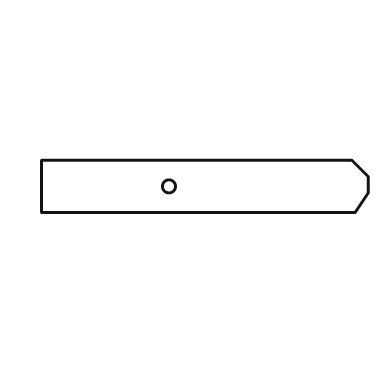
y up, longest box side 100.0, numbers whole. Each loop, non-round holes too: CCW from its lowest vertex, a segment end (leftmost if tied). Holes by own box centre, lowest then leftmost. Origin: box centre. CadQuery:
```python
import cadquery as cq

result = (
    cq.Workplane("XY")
    .moveTo(-50.0, -8.0)
    .lineTo(46.0, -8.0)
    .lineTo(50.0, -2.0)
    .lineTo(50.0, 3.0)
    .lineTo(45.0, 8.0)
    .lineTo(-50.0, 8.0)
    .close()
    .moveTo(-11.0, 0.0)
    .circle(2.0)
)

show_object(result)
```